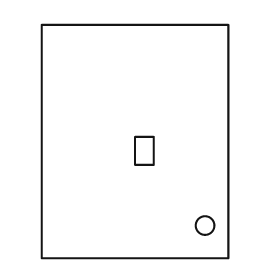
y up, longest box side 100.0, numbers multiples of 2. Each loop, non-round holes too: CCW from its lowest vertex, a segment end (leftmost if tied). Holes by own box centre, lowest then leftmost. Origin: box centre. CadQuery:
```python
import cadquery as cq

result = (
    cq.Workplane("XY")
    .moveTo(-40.0, -50.0)
    .lineTo(40.0, -50.0)
    .lineTo(40.0, 50.0)
    .lineTo(-40.0, 50.0)
    .close()
    .moveTo(30.0, -36.0)
    .circle(4.0)
    .moveTo(0.0, -10.0)
    .lineTo(8.0, -10.0)
    .lineTo(8.0, 2.0)
    .lineTo(0.0, 2.0)
    .close()
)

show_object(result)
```